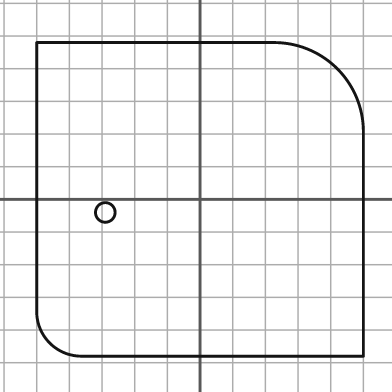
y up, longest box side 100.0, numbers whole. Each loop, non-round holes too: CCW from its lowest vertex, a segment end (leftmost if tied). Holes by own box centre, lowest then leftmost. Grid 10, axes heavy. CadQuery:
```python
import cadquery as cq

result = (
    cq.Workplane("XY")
    .moveTo(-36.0, -48.0)
    .lineTo(50.0, -48.0)
    .lineTo(50.0, 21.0)
    .threePointArc((42.0, 40.0), (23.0, 48.0))
    .lineTo(-50.0, 48.0)
    .lineTo(-50.0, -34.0)
    .threePointArc((-46.0, -44.0), (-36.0, -48.0))
    .close()
    .moveTo(-29.0, -4.0)
    .circle(3.0)
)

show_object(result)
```